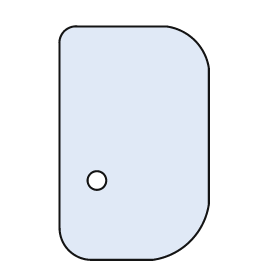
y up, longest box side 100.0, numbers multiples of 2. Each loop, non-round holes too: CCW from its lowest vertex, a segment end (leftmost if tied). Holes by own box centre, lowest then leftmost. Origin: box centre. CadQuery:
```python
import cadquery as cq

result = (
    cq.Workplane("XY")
    .moveTo(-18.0, -50.0)
    .lineTo(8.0, -50.0)
    .threePointArc((24.0, -42.0), (32.0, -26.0))
    .lineTo(32.0, 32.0)
    .threePointArc((26.0, 44.0), (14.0, 50.0))
    .lineTo(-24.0, 50.0)
    .threePointArc((-30.0, 48.0), (-32.0, 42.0))
    .lineTo(-32.0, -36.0)
    .threePointArc((-28.0, -46.0), (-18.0, -50.0))
    .close()
    .moveTo(-16.0, -16.0)
    .circle(4.0)
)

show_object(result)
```